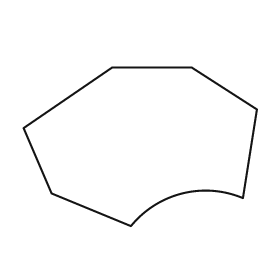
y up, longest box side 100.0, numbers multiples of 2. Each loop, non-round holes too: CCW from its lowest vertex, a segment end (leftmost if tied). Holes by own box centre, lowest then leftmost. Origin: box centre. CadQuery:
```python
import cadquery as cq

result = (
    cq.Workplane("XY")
    .moveTo(-4.0, -34.0)
    .threePointArc((18.0, -20.0), (44.0, -22.0))
    .lineTo(50.0, 16.0)
    .lineTo(22.0, 34.0)
    .lineTo(-12.0, 34.0)
    .lineTo(-50.0, 8.0)
    .lineTo(-38.0, -20.0)
    .close()
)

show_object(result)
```